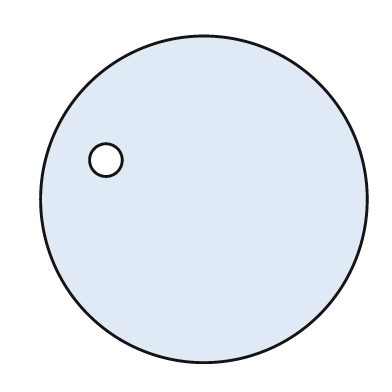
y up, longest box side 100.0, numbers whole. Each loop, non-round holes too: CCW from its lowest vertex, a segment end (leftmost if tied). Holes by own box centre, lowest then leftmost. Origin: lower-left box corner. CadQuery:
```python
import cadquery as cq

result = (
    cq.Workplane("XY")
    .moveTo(50.0, 50.0)
    .circle(50.0)
    .moveTo(20.0, 62.0)
    .circle(5.0)
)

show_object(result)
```